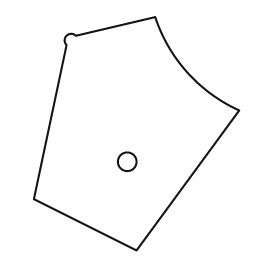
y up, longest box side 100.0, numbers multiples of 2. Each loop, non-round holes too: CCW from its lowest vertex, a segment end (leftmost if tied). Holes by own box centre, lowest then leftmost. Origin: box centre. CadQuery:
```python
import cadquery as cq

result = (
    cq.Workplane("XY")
    .moveTo(0.0, -50.0)
    .lineTo(44.0, 10.0)
    .threePointArc((22.0, 26.0), (8.0, 50.0))
    .lineTo(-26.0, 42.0)
    .threePointArc((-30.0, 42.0), (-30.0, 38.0))
    .lineTo(-44.0, -28.0)
    .close()
    .moveTo(-4.0, -12.0)
    .circle(4.0)
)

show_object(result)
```